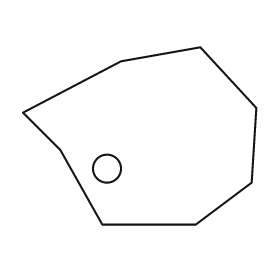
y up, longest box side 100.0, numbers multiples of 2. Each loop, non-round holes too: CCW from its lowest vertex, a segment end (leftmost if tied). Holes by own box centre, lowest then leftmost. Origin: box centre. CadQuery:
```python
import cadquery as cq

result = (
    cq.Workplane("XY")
    .moveTo(-16.0, -38.0)
    .lineTo(24.0, -38.0)
    .lineTo(48.0, -20.0)
    .lineTo(50.0, 12.0)
    .lineTo(26.0, 38.0)
    .lineTo(-8.0, 32.0)
    .lineTo(-50.0, 10.0)
    .lineTo(-34.0, -6.0)
    .close()
    .moveTo(-14.0, -14.0)
    .circle(6.0)
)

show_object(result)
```